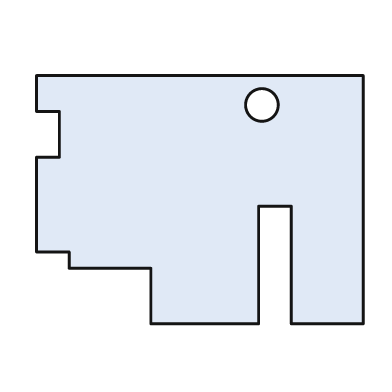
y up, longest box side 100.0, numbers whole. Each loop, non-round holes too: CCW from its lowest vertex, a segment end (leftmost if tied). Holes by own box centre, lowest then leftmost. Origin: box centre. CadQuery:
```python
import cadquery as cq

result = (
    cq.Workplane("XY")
    .moveTo(-15.0, -38.0)
    .lineTo(18.0, -38.0)
    .lineTo(18.0, -2.0)
    .lineTo(28.0, -2.0)
    .lineTo(28.0, -38.0)
    .lineTo(50.0, -38.0)
    .lineTo(50.0, 38.0)
    .lineTo(-50.0, 38.0)
    .lineTo(-50.0, 27.0)
    .lineTo(-43.0, 27.0)
    .lineTo(-43.0, 13.0)
    .lineTo(-50.0, 13.0)
    .lineTo(-50.0, -16.0)
    .lineTo(-40.0, -16.0)
    .lineTo(-40.0, -21.0)
    .lineTo(-15.0, -21.0)
    .close()
    .moveTo(19.0, 29.0)
    .circle(5.0)
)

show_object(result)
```